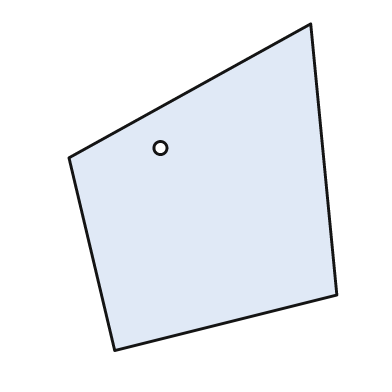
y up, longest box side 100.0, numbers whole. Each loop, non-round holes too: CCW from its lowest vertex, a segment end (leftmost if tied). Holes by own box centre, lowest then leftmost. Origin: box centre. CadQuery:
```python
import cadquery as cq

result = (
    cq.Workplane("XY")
    .moveTo(-27.0, -50.0)
    .lineTo(41.0, -33.0)
    .lineTo(33.0, 50.0)
    .lineTo(-41.0, 9.0)
    .close()
    .moveTo(-13.0, 12.0)
    .circle(2.0)
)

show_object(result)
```